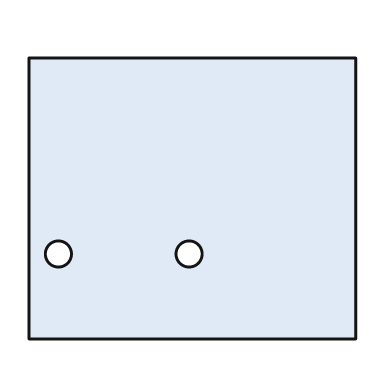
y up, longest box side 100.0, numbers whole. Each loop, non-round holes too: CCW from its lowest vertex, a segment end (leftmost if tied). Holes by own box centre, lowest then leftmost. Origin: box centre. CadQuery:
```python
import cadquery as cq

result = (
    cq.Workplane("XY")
    .moveTo(-50.0, -43.0)
    .lineTo(50.0, -43.0)
    .lineTo(50.0, 43.0)
    .lineTo(-50.0, 43.0)
    .close()
    .moveTo(-41.0, -17.0)
    .circle(4.0)
    .moveTo(-1.0, -17.0)
    .circle(4.0)
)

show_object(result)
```